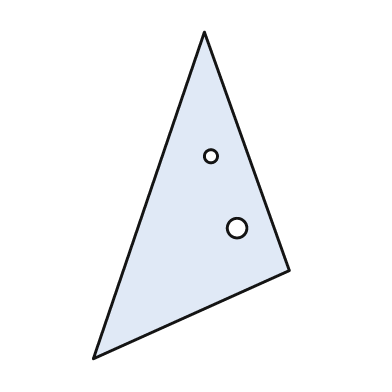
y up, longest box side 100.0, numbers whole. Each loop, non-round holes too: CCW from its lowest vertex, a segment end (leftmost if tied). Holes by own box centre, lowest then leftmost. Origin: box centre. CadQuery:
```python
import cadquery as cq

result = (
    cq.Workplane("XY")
    .moveTo(-30.0, -50.0)
    .lineTo(30.0, -23.0)
    .lineTo(4.0, 50.0)
    .close()
    .moveTo(14.0, -10.0)
    .circle(3.0)
    .moveTo(6.0, 12.0)
    .circle(2.0)
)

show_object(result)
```